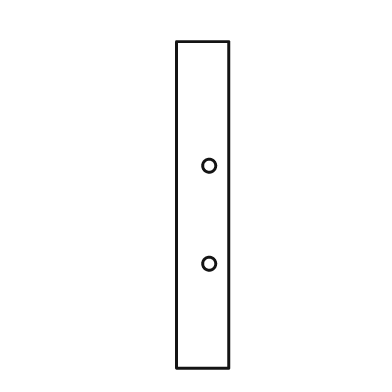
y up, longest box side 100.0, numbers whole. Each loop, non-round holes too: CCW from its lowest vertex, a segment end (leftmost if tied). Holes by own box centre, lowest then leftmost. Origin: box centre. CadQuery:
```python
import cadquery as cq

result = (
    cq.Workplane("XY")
    .moveTo(-8.0, -50.0)
    .lineTo(8.0, -50.0)
    .lineTo(8.0, 50.0)
    .lineTo(-8.0, 50.0)
    .close()
    .moveTo(2.0, -18.0)
    .circle(2.0)
    .moveTo(2.0, 12.0)
    .circle(2.0)
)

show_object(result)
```